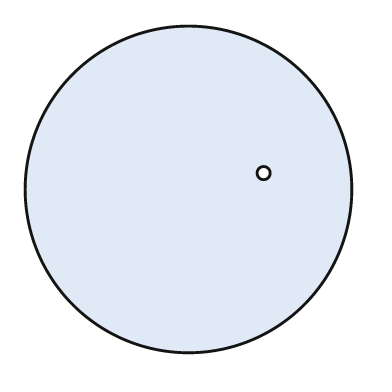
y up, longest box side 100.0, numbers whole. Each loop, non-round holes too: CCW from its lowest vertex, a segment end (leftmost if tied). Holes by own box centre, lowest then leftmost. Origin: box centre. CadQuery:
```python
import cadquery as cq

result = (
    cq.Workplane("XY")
    .moveTo(0.0, 0.0)
    .circle(50.0)
    .moveTo(23.0, 5.0)
    .circle(2.0)
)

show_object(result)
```